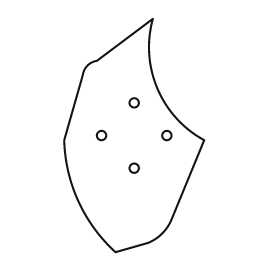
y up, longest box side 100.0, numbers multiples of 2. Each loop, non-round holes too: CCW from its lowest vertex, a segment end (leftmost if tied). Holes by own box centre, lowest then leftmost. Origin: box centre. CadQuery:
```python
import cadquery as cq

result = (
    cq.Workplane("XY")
    .moveTo(-8.0, -50.0)
    .lineTo(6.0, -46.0)
    .threePointArc((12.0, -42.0), (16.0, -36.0))
    .lineTo(30.0, -2.0)
    .threePointArc((10.0, 20.0), (8.0, 50.0))
    .lineTo(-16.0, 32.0)
    .threePointArc((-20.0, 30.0), (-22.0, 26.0))
    .lineTo(-30.0, -2.0)
    .threePointArc((-24.0, -28.0), (-8.0, -50.0))
    .close()
    .moveTo(0.0, -14.0)
    .circle(2.0)
    .moveTo(-14.0, 0.0)
    .circle(2.0)
    .moveTo(14.0, 0.0)
    .circle(2.0)
    .moveTo(0.0, 14.0)
    .circle(2.0)
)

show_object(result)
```